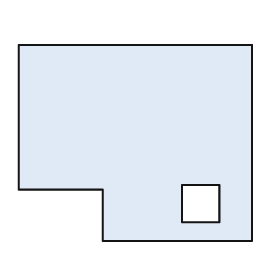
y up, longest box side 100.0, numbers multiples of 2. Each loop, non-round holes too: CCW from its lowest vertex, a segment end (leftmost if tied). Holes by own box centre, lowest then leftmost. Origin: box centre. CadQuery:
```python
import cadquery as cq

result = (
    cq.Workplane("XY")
    .moveTo(-14.0, -42.0)
    .lineTo(50.0, -42.0)
    .lineTo(50.0, 42.0)
    .lineTo(-50.0, 42.0)
    .lineTo(-50.0, -20.0)
    .lineTo(-14.0, -20.0)
    .close()
    .moveTo(20.0, -34.0)
    .lineTo(36.0, -34.0)
    .lineTo(36.0, -18.0)
    .lineTo(20.0, -18.0)
    .close()
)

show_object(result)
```